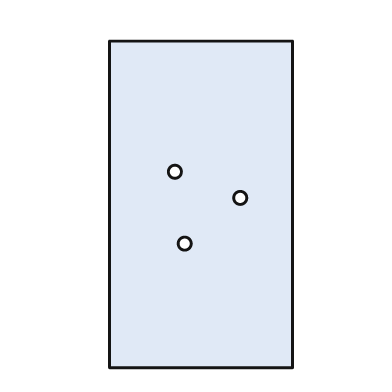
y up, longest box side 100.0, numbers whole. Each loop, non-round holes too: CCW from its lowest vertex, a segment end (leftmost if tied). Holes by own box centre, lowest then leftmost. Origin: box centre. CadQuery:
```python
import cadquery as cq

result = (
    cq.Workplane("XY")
    .moveTo(-28.0, -50.0)
    .lineTo(28.0, -50.0)
    .lineTo(28.0, 50.0)
    .lineTo(-28.0, 50.0)
    .close()
    .moveTo(-5.0, -12.0)
    .circle(2.0)
    .moveTo(12.0, 2.0)
    .circle(2.0)
    .moveTo(-8.0, 10.0)
    .circle(2.0)
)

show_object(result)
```